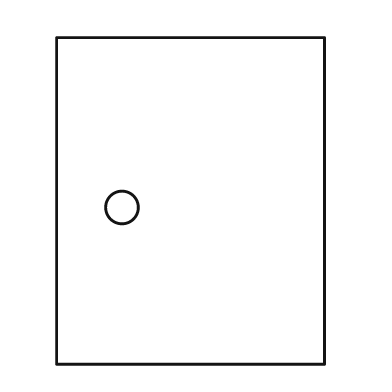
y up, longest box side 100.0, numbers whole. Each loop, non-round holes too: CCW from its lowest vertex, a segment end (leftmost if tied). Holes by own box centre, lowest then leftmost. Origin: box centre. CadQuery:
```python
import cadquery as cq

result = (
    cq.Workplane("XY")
    .moveTo(-41.0, -50.0)
    .lineTo(41.0, -50.0)
    .lineTo(41.0, 50.0)
    .lineTo(-41.0, 50.0)
    .close()
    .moveTo(-21.0, -2.0)
    .circle(5.0)
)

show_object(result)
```